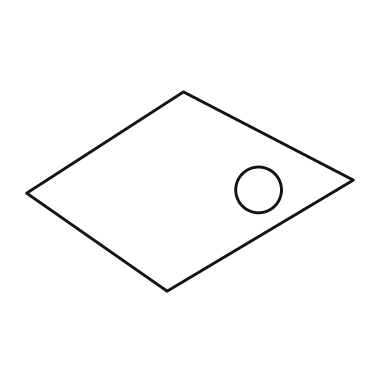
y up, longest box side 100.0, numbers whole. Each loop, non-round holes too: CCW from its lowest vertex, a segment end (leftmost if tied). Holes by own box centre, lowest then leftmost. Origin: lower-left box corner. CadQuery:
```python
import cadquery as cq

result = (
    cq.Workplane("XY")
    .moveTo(43.0, 0.0)
    .lineTo(100.0, 34.0)
    .lineTo(48.0, 61.0)
    .lineTo(0.0, 30.0)
    .close()
    .moveTo(71.0, 31.0)
    .circle(7.0)
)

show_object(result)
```